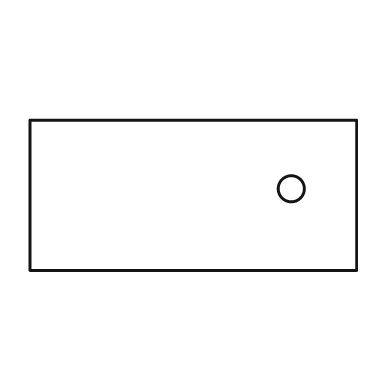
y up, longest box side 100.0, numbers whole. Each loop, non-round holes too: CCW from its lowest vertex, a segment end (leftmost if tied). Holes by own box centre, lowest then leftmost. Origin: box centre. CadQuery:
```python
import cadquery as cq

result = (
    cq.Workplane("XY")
    .moveTo(-50.0, -23.0)
    .lineTo(50.0, -23.0)
    .lineTo(50.0, 23.0)
    .lineTo(-50.0, 23.0)
    .close()
    .moveTo(30.0, 2.0)
    .circle(4.0)
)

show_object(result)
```